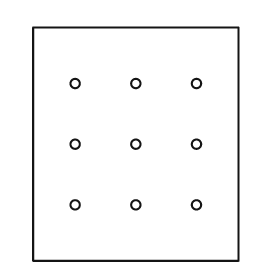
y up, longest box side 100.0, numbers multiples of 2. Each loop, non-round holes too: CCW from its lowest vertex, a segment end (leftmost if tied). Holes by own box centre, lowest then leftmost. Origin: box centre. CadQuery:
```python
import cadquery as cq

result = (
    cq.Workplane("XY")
    .moveTo(-44.0, -50.0)
    .lineTo(44.0, -50.0)
    .lineTo(44.0, 50.0)
    .lineTo(-44.0, 50.0)
    .close()
    .moveTo(-26.0, -26.0)
    .circle(2.0)
    .moveTo(0.0, -26.0)
    .circle(2.0)
    .moveTo(26.0, -26.0)
    .circle(2.0)
    .moveTo(-26.0, 0.0)
    .circle(2.0)
    .moveTo(0.0, 0.0)
    .circle(2.0)
    .moveTo(26.0, 0.0)
    .circle(2.0)
    .moveTo(-26.0, 26.0)
    .circle(2.0)
    .moveTo(0.0, 26.0)
    .circle(2.0)
    .moveTo(26.0, 26.0)
    .circle(2.0)
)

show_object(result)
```